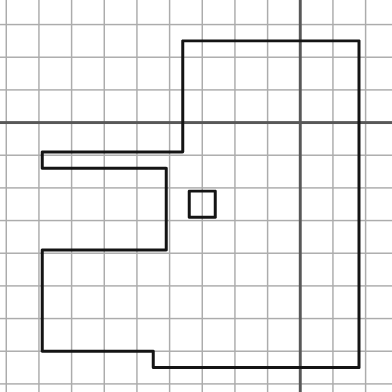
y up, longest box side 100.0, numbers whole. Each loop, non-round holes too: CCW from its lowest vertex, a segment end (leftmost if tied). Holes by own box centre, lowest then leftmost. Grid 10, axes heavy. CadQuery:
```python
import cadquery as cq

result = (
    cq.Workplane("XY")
    .moveTo(-45.0, -75.0)
    .lineTo(18.0, -75.0)
    .lineTo(18.0, 25.0)
    .lineTo(-36.0, 25.0)
    .lineTo(-36.0, -9.0)
    .lineTo(-79.0, -9.0)
    .lineTo(-79.0, -14.0)
    .lineTo(-41.0, -14.0)
    .lineTo(-41.0, -39.0)
    .lineTo(-79.0, -39.0)
    .lineTo(-79.0, -70.0)
    .lineTo(-45.0, -70.0)
    .close()
    .moveTo(-34.0, -29.0)
    .lineTo(-26.0, -29.0)
    .lineTo(-26.0, -21.0)
    .lineTo(-34.0, -21.0)
    .close()
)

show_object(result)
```